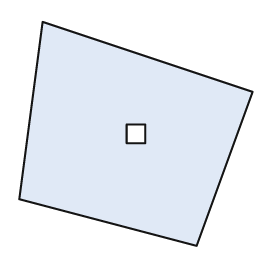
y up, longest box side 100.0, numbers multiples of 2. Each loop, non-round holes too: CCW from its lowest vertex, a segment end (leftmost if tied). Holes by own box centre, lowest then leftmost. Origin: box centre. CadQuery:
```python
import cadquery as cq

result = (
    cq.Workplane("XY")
    .moveTo(26.0, -48.0)
    .lineTo(50.0, 18.0)
    .lineTo(-40.0, 48.0)
    .lineTo(-50.0, -28.0)
    .close()
    .moveTo(-4.0, -4.0)
    .lineTo(4.0, -4.0)
    .lineTo(4.0, 4.0)
    .lineTo(-4.0, 4.0)
    .close()
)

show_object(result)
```